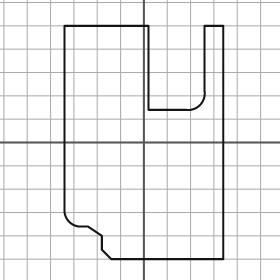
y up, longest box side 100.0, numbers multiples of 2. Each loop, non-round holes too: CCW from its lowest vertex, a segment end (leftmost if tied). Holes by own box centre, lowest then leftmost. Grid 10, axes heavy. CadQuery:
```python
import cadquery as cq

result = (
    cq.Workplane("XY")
    .moveTo(-14.0, -50.0)
    .lineTo(34.0, -50.0)
    .lineTo(34.0, 50.0)
    .lineTo(26.0, 50.0)
    .lineTo(26.0, 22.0)
    .threePointArc((24.0, 16.0), (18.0, 14.0))
    .lineTo(2.0, 14.0)
    .lineTo(2.0, 50.0)
    .lineTo(-34.0, 50.0)
    .lineTo(-34.0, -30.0)
    .threePointArc((-32.0, -34.0), (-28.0, -36.0))
    .lineTo(-24.0, -36.0)
    .lineTo(-18.0, -40.0)
    .lineTo(-18.0, -46.0)
    .close()
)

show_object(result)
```